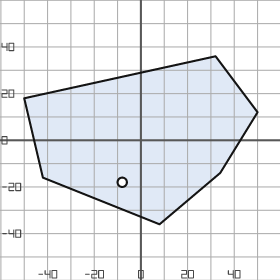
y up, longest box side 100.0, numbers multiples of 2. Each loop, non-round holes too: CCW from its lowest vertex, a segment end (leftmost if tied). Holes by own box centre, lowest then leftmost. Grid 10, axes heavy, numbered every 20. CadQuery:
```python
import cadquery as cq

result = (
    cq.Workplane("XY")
    .moveTo(8.0, -36.0)
    .lineTo(34.0, -14.0)
    .lineTo(50.0, 12.0)
    .lineTo(32.0, 36.0)
    .lineTo(-50.0, 18.0)
    .lineTo(-42.0, -16.0)
    .close()
    .moveTo(-8.0, -18.0)
    .circle(2.0)
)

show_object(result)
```